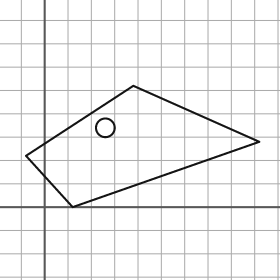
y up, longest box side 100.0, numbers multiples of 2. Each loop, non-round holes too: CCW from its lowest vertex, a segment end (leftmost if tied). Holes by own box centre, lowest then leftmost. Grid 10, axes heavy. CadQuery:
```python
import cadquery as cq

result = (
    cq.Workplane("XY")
    .moveTo(12.0, 0.0)
    .lineTo(92.0, 28.0)
    .lineTo(38.0, 52.0)
    .lineTo(-8.0, 22.0)
    .close()
    .moveTo(26.0, 34.0)
    .circle(4.0)
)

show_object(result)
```